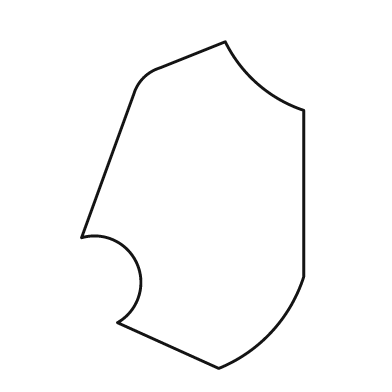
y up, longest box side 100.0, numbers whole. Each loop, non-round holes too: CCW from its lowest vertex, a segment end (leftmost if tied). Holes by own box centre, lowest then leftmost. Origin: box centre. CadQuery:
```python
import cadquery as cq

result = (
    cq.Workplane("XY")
    .moveTo(8.0, -50.0)
    .threePointArc((24.0, -39.0), (34.0, -22.0))
    .lineTo(34.0, 29.0)
    .threePointArc((20.0, 37.0), (10.0, 50.0))
    .lineTo(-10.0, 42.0)
    .threePointArc((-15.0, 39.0), (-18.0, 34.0))
    .lineTo(-34.0, -10.0)
    .threePointArc((-17.0, -18.0), (-23.0, -36.0))
    .close()
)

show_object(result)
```